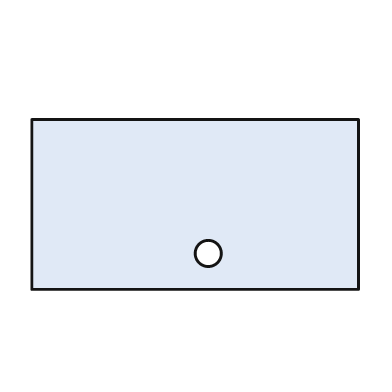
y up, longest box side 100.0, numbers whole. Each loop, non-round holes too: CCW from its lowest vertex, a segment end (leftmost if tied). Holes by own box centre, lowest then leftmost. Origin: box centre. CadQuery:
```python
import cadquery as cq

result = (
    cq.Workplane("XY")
    .moveTo(-50.0, -26.0)
    .lineTo(50.0, -26.0)
    .lineTo(50.0, 26.0)
    .lineTo(-50.0, 26.0)
    .close()
    .moveTo(4.0, -15.0)
    .circle(4.0)
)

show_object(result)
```